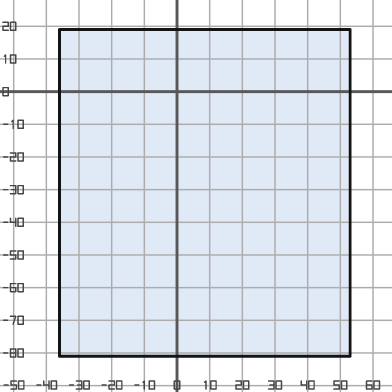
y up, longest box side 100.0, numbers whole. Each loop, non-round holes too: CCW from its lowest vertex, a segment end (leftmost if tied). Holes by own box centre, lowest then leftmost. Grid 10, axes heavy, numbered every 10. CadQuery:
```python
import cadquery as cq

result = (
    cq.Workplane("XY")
    .moveTo(-36.0, -81.0)
    .lineTo(53.0, -81.0)
    .lineTo(53.0, 19.0)
    .lineTo(-36.0, 19.0)
    .close()
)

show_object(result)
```